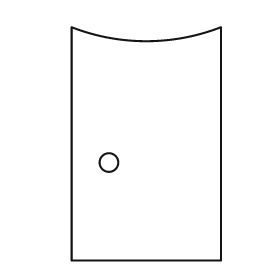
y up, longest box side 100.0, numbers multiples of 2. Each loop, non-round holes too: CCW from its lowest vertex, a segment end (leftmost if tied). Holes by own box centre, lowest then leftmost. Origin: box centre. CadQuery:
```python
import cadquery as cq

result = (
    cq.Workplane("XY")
    .moveTo(-32.0, -50.0)
    .lineTo(32.0, -50.0)
    .lineTo(32.0, 50.0)
    .threePointArc((0.0, 44.0), (-32.0, 50.0))
    .close()
    .moveTo(-16.0, -8.0)
    .circle(4.0)
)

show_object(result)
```